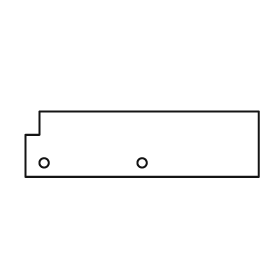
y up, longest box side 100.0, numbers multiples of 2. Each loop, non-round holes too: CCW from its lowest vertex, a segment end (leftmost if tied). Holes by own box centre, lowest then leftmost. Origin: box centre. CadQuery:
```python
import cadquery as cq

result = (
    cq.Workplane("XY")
    .moveTo(-50.0, -14.0)
    .lineTo(50.0, -14.0)
    .lineTo(50.0, 14.0)
    .lineTo(-44.0, 14.0)
    .lineTo(-44.0, 4.0)
    .lineTo(-50.0, 4.0)
    .close()
    .moveTo(-42.0, -8.0)
    .circle(2.0)
    .moveTo(0.0, -8.0)
    .circle(2.0)
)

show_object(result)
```